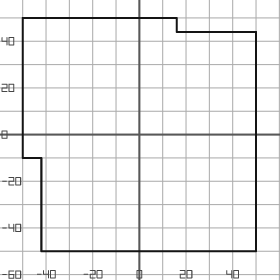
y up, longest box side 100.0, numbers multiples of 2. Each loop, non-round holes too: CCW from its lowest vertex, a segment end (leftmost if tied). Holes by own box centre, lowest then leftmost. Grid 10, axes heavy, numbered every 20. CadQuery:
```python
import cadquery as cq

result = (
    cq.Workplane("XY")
    .moveTo(-42.0, -50.0)
    .lineTo(50.0, -50.0)
    .lineTo(50.0, 44.0)
    .lineTo(16.0, 44.0)
    .lineTo(16.0, 50.0)
    .lineTo(-50.0, 50.0)
    .lineTo(-50.0, -10.0)
    .lineTo(-42.0, -10.0)
    .close()
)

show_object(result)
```